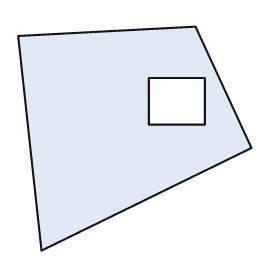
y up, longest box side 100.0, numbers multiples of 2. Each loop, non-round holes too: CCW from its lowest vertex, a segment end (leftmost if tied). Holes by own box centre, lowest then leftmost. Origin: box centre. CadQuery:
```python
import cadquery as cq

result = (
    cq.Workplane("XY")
    .moveTo(-40.0, -48.0)
    .lineTo(50.0, -4.0)
    .lineTo(26.0, 48.0)
    .lineTo(-50.0, 44.0)
    .close()
    .moveTo(6.0, 6.0)
    .lineTo(30.0, 6.0)
    .lineTo(30.0, 26.0)
    .lineTo(6.0, 26.0)
    .close()
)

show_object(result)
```